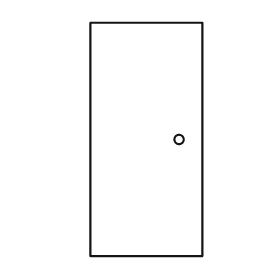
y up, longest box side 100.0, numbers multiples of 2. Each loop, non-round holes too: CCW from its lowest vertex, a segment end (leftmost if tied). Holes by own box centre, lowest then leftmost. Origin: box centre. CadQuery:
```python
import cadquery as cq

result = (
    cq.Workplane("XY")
    .moveTo(-24.0, -50.0)
    .lineTo(24.0, -50.0)
    .lineTo(24.0, 50.0)
    .lineTo(-24.0, 50.0)
    .close()
    .moveTo(14.0, 0.0)
    .circle(2.0)
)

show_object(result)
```